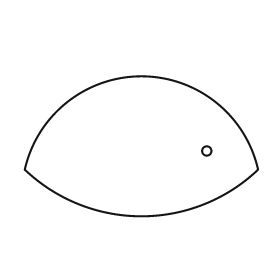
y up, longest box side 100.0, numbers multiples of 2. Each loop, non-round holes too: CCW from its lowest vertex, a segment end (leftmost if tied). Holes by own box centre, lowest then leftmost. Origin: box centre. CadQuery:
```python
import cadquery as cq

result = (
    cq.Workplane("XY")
    .moveTo(-50.0, -10.0)
    .threePointArc((0.0, -30.0), (50.0, -10.0))
    .threePointArc((0.0, 30.0), (-50.0, -10.0))
    .close()
    .moveTo(28.0, -2.0)
    .circle(2.0)
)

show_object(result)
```